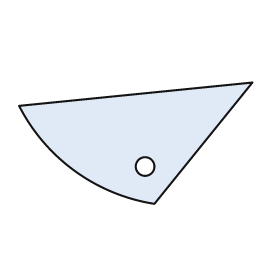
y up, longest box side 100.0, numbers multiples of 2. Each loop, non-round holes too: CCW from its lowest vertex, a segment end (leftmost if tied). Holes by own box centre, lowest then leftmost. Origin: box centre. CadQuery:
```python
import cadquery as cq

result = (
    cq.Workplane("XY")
    .moveTo(8.0, -26.0)
    .lineTo(50.0, 26.0)
    .lineTo(-50.0, 16.0)
    .threePointArc((-26.0, -12.0), (8.0, -26.0))
    .close()
    .moveTo(4.0, -10.0)
    .circle(4.0)
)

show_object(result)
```